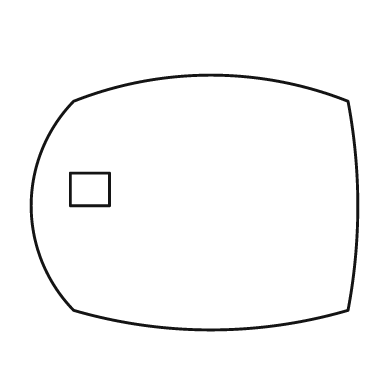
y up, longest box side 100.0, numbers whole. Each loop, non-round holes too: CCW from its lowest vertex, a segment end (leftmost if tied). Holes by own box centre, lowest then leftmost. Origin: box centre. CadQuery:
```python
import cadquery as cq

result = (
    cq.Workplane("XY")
    .moveTo(-37.0, -33.0)
    .threePointArc((5.0, -39.0), (47.0, -33.0))
    .threePointArc((50.0, -1.0), (47.0, 31.0))
    .threePointArc((5.0, 39.0), (-37.0, 31.0))
    .threePointArc((-50.0, -1.0), (-37.0, -33.0))
    .close()
    .moveTo(-38.0, -1.0)
    .lineTo(-26.0, -1.0)
    .lineTo(-26.0, 9.0)
    .lineTo(-38.0, 9.0)
    .close()
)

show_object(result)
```